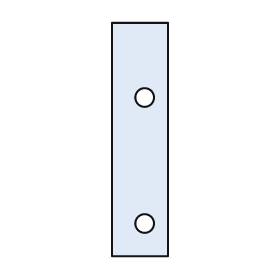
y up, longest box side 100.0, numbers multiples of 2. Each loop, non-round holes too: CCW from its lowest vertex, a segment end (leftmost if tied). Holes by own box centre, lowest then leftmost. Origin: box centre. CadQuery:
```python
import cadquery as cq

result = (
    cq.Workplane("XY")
    .moveTo(-12.0, -50.0)
    .lineTo(12.0, -50.0)
    .lineTo(12.0, 50.0)
    .lineTo(-12.0, 50.0)
    .close()
    .moveTo(2.0, -36.0)
    .circle(4.0)
    .moveTo(2.0, 18.0)
    .circle(4.0)
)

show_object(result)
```